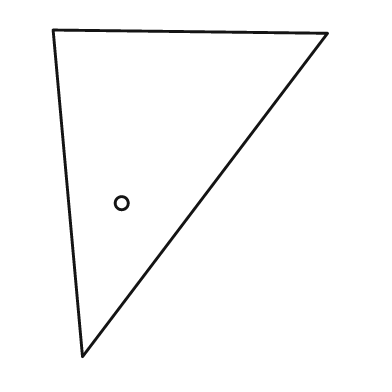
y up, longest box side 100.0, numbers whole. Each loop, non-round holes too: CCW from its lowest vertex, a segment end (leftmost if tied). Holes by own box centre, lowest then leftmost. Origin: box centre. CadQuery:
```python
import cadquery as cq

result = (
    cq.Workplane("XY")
    .moveTo(-33.0, -50.0)
    .lineTo(42.0, 49.0)
    .lineTo(-42.0, 50.0)
    .close()
    .moveTo(-21.0, -3.0)
    .circle(2.0)
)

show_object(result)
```